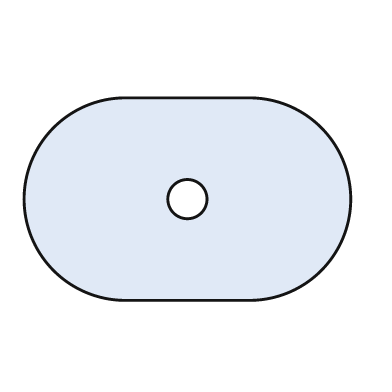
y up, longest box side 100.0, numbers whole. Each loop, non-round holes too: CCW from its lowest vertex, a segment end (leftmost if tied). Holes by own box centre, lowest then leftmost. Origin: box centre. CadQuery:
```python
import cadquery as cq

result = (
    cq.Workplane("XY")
    .moveTo(-19.0, -31.0)
    .lineTo(19.0, -31.0)
    .threePointArc((50.0, 0.0), (19.0, 31.0))
    .lineTo(-19.0, 31.0)
    .threePointArc((-50.0, 0.0), (-19.0, -31.0))
    .close()
    .moveTo(0.0, 0.0)
    .circle(6.0)
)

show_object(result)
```